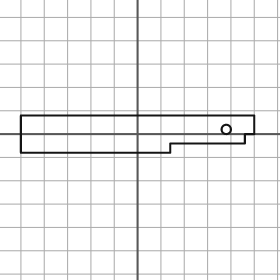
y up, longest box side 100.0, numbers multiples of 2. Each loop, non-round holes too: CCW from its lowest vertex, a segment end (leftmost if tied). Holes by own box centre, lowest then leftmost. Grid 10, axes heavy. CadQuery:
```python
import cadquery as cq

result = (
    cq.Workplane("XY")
    .moveTo(-50.0, -8.0)
    .lineTo(14.0, -8.0)
    .lineTo(14.0, -4.0)
    .lineTo(46.0, -4.0)
    .lineTo(46.0, 0.0)
    .lineTo(50.0, 0.0)
    .lineTo(50.0, 8.0)
    .lineTo(-50.0, 8.0)
    .close()
    .moveTo(38.0, 2.0)
    .circle(2.0)
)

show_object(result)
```